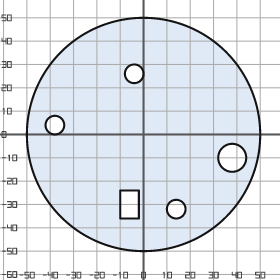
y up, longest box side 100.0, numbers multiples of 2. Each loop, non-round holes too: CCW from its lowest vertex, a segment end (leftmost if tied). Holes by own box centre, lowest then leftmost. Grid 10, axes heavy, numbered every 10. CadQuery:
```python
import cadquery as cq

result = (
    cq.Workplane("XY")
    .moveTo(0.0, 0.0)
    .circle(50.0)
    .moveTo(14.0, -32.0)
    .circle(4.0)
    .moveTo(-10.0, -36.0)
    .lineTo(-2.0, -36.0)
    .lineTo(-2.0, -24.0)
    .lineTo(-10.0, -24.0)
    .close()
    .moveTo(38.0, -10.0)
    .circle(6.0)
    .moveTo(-38.0, 4.0)
    .circle(4.0)
    .moveTo(-4.0, 26.0)
    .circle(4.0)
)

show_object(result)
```